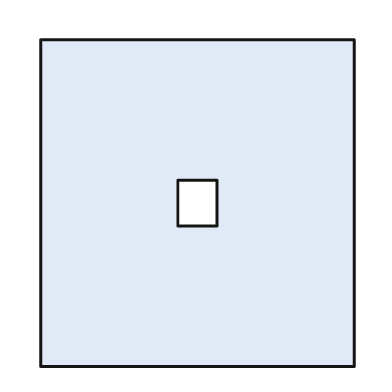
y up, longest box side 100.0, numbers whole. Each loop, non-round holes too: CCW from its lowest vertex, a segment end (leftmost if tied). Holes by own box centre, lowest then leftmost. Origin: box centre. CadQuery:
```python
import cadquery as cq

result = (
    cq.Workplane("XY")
    .moveTo(-48.0, -50.0)
    .lineTo(48.0, -50.0)
    .lineTo(48.0, 50.0)
    .lineTo(-48.0, 50.0)
    .close()
    .moveTo(-6.0, -7.0)
    .lineTo(6.0, -7.0)
    .lineTo(6.0, 7.0)
    .lineTo(-6.0, 7.0)
    .close()
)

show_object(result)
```